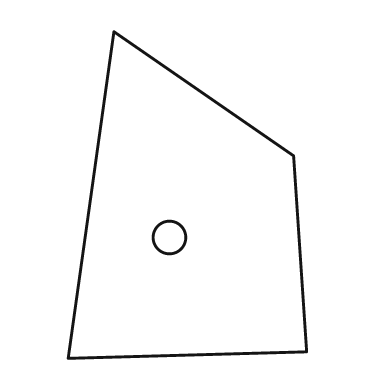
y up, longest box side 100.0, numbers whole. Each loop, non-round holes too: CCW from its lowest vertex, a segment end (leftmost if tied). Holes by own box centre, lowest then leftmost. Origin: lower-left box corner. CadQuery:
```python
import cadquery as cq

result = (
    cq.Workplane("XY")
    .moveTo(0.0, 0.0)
    .lineTo(73.0, 2.0)
    .lineTo(69.0, 62.0)
    .lineTo(14.0, 100.0)
    .close()
    .moveTo(31.0, 37.0)
    .circle(5.0)
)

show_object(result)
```